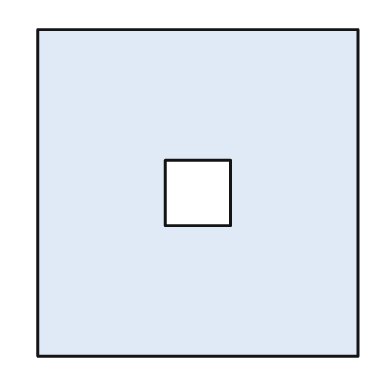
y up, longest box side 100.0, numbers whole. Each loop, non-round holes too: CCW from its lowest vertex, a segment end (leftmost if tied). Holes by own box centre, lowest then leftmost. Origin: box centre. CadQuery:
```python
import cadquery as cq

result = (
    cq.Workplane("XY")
    .moveTo(-49.0, -50.0)
    .lineTo(49.0, -50.0)
    .lineTo(49.0, 50.0)
    .lineTo(-49.0, 50.0)
    .close()
    .moveTo(-10.0, -10.0)
    .lineTo(10.0, -10.0)
    .lineTo(10.0, 10.0)
    .lineTo(-10.0, 10.0)
    .close()
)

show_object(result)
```